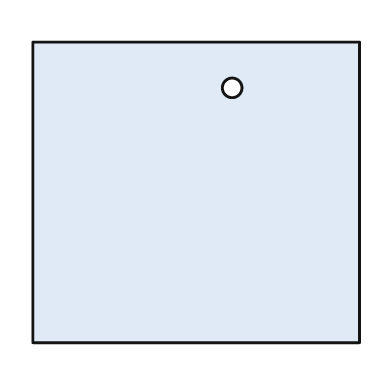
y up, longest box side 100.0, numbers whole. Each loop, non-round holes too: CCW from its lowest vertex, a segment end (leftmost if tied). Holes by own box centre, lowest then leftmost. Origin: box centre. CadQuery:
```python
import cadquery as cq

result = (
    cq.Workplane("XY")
    .moveTo(-50.0, -46.0)
    .lineTo(50.0, -46.0)
    .lineTo(50.0, 46.0)
    .lineTo(-50.0, 46.0)
    .close()
    .moveTo(11.0, 32.0)
    .circle(3.0)
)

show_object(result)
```